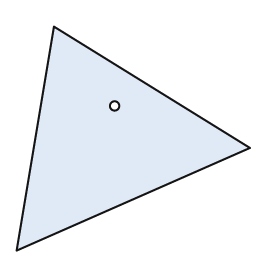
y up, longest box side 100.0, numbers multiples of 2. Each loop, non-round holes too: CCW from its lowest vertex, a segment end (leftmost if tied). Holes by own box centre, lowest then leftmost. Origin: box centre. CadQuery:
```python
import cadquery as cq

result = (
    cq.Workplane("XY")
    .moveTo(-50.0, -48.0)
    .lineTo(50.0, -4.0)
    .lineTo(-34.0, 48.0)
    .close()
    .moveTo(-8.0, 14.0)
    .circle(2.0)
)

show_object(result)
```